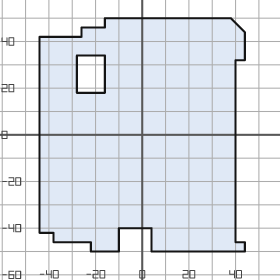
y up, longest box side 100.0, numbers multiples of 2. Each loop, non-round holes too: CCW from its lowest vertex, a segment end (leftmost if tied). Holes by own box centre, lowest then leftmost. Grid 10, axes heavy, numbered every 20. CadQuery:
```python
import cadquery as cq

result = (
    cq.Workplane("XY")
    .moveTo(-22.0, -50.0)
    .lineTo(-10.0, -50.0)
    .lineTo(-10.0, -40.0)
    .lineTo(4.0, -40.0)
    .lineTo(4.0, -50.0)
    .lineTo(44.0, -50.0)
    .lineTo(44.0, -46.0)
    .lineTo(40.0, -46.0)
    .lineTo(40.0, 32.0)
    .lineTo(44.0, 32.0)
    .lineTo(44.0, 44.0)
    .lineTo(38.0, 50.0)
    .lineTo(-16.0, 50.0)
    .lineTo(-16.0, 46.0)
    .lineTo(-26.0, 46.0)
    .lineTo(-26.0, 42.0)
    .lineTo(-44.0, 42.0)
    .lineTo(-44.0, -42.0)
    .lineTo(-38.0, -42.0)
    .lineTo(-38.0, -46.0)
    .lineTo(-22.0, -46.0)
    .close()
    .moveTo(-28.0, 18.0)
    .lineTo(-16.0, 18.0)
    .lineTo(-16.0, 34.0)
    .lineTo(-28.0, 34.0)
    .close()
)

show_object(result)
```